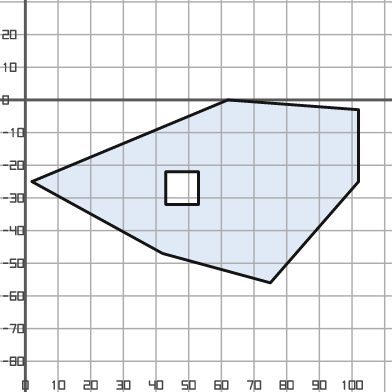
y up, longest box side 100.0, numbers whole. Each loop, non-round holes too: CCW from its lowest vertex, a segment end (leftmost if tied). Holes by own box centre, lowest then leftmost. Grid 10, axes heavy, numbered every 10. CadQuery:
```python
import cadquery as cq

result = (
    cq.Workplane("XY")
    .moveTo(75.0, -56.0)
    .lineTo(102.0, -25.0)
    .lineTo(102.0, -3.0)
    .lineTo(62.0, 0.0)
    .lineTo(2.0, -25.0)
    .lineTo(42.0, -47.0)
    .close()
    .moveTo(43.0, -32.0)
    .lineTo(53.0, -32.0)
    .lineTo(53.0, -22.0)
    .lineTo(43.0, -22.0)
    .close()
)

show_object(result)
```